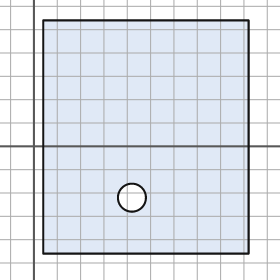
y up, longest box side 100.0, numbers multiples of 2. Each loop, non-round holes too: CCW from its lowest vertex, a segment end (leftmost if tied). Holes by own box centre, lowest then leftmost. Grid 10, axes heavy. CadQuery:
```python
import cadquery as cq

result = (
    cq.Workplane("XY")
    .moveTo(4.0, -46.0)
    .lineTo(92.0, -46.0)
    .lineTo(92.0, 54.0)
    .lineTo(4.0, 54.0)
    .close()
    .moveTo(42.0, -22.0)
    .circle(6.0)
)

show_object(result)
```